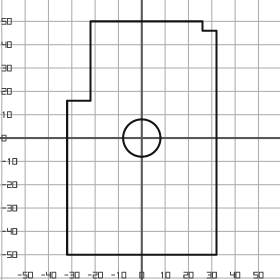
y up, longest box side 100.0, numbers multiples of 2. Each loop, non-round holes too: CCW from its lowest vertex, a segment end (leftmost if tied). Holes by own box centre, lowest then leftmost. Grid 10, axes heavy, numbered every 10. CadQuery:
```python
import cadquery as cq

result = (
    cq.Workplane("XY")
    .moveTo(-32.0, -50.0)
    .lineTo(32.0, -50.0)
    .lineTo(32.0, 46.0)
    .lineTo(26.0, 46.0)
    .lineTo(26.0, 50.0)
    .lineTo(-22.0, 50.0)
    .lineTo(-22.0, 16.0)
    .lineTo(-32.0, 16.0)
    .close()
    .moveTo(0.0, 0.0)
    .circle(8.0)
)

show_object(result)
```